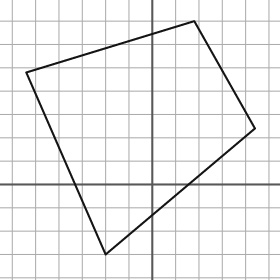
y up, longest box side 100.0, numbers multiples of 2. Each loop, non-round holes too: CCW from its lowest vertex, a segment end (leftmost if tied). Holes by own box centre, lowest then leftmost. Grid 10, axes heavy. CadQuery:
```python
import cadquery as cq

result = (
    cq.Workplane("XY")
    .moveTo(-20.0, -30.0)
    .lineTo(44.0, 24.0)
    .lineTo(18.0, 70.0)
    .lineTo(-54.0, 48.0)
    .close()
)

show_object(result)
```